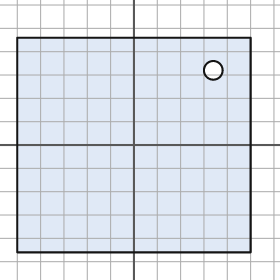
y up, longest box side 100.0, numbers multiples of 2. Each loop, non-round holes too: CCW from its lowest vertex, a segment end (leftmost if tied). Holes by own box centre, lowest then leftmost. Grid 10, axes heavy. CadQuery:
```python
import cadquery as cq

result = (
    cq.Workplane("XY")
    .moveTo(-50.0, -46.0)
    .lineTo(50.0, -46.0)
    .lineTo(50.0, 46.0)
    .lineTo(-50.0, 46.0)
    .close()
    .moveTo(34.0, 32.0)
    .circle(4.0)
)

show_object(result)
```